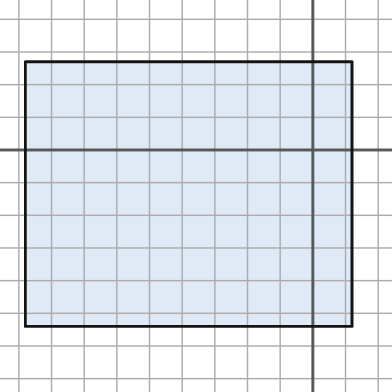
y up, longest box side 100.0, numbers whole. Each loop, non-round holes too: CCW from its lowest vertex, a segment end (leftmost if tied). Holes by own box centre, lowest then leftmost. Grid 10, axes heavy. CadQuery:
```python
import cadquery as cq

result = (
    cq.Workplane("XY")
    .moveTo(-88.0, -54.0)
    .lineTo(12.0, -54.0)
    .lineTo(12.0, 27.0)
    .lineTo(-88.0, 27.0)
    .close()
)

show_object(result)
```